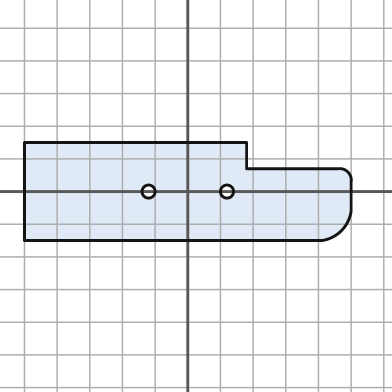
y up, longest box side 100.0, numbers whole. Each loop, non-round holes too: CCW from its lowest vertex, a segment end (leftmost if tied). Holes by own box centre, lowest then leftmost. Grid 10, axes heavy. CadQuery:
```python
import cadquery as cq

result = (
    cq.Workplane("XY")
    .moveTo(-50.0, -15.0)
    .lineTo(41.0, -15.0)
    .threePointArc((47.0, -12.0), (50.0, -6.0))
    .lineTo(50.0, 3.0)
    .threePointArc((49.0, 6.0), (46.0, 7.0))
    .lineTo(18.0, 7.0)
    .lineTo(18.0, 15.0)
    .lineTo(-50.0, 15.0)
    .close()
    .moveTo(-12.0, 0.0)
    .circle(2.0)
    .moveTo(12.0, 0.0)
    .circle(2.0)
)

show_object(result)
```